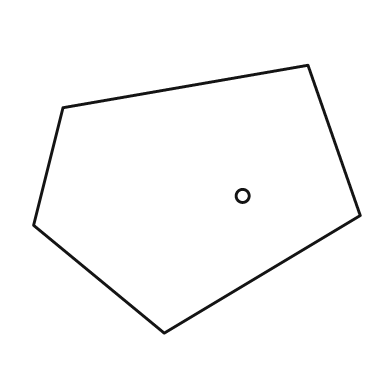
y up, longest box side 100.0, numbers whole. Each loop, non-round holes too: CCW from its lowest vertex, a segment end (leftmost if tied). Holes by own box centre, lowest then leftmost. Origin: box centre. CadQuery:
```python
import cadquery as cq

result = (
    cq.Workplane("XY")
    .moveTo(-10.0, -41.0)
    .lineTo(50.0, -5.0)
    .lineTo(34.0, 41.0)
    .lineTo(-41.0, 28.0)
    .lineTo(-50.0, -8.0)
    .close()
    .moveTo(14.0, 1.0)
    .circle(2.0)
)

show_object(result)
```